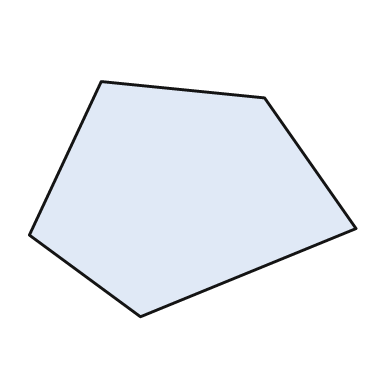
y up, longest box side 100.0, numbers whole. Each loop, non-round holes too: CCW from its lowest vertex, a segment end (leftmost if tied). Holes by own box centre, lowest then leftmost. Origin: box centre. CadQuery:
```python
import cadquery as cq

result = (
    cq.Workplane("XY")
    .moveTo(-16.0, -36.0)
    .lineTo(50.0, -9.0)
    .lineTo(22.0, 31.0)
    .lineTo(-28.0, 36.0)
    .lineTo(-50.0, -11.0)
    .close()
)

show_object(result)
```